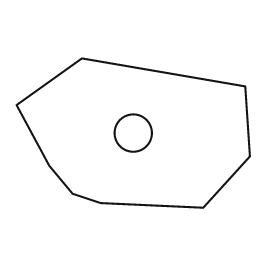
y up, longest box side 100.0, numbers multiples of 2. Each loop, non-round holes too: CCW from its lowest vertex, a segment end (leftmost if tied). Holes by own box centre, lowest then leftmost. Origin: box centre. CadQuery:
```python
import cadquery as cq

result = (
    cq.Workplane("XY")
    .moveTo(30.0, -32.0)
    .lineTo(50.0, -10.0)
    .lineTo(48.0, 20.0)
    .lineTo(-22.0, 32.0)
    .lineTo(-50.0, 12.0)
    .lineTo(-36.0, -14.0)
    .lineTo(-26.0, -26.0)
    .lineTo(-14.0, -30.0)
    .close()
    .moveTo(0.0, 0.0)
    .circle(8.0)
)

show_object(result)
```